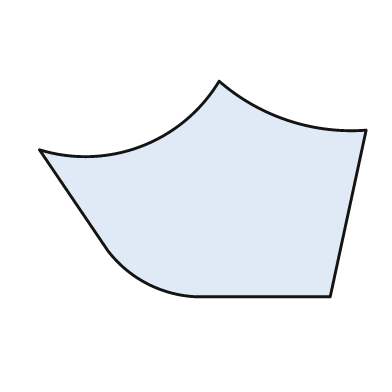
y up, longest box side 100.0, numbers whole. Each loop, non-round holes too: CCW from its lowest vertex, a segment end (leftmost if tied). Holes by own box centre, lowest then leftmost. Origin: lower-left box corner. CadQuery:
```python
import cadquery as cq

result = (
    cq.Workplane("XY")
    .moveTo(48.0, 0.0)
    .lineTo(89.0, 0.0)
    .lineTo(100.0, 51.0)
    .threePointArc((76.0, 54.0), (55.0, 66.0))
    .threePointArc((31.0, 46.0), (0.0, 45.0))
    .lineTo(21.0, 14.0)
    .threePointArc((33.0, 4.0), (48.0, 0.0))
    .close()
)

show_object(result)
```